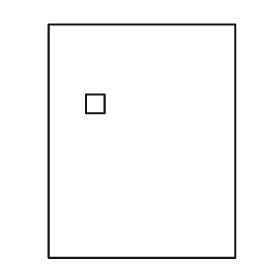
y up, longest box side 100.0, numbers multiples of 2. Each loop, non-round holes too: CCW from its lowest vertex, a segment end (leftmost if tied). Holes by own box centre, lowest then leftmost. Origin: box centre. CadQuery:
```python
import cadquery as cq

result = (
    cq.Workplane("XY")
    .moveTo(-40.0, -50.0)
    .lineTo(40.0, -50.0)
    .lineTo(40.0, 50.0)
    .lineTo(-40.0, 50.0)
    .close()
    .moveTo(-24.0, 12.0)
    .lineTo(-16.0, 12.0)
    .lineTo(-16.0, 20.0)
    .lineTo(-24.0, 20.0)
    .close()
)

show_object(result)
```